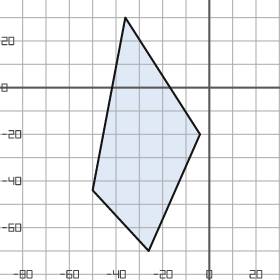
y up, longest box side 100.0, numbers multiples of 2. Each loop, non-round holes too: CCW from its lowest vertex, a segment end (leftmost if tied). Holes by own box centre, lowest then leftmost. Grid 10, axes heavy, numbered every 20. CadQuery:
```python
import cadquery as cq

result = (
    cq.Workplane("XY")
    .moveTo(-26.0, -70.0)
    .lineTo(-4.0, -20.0)
    .lineTo(-36.0, 30.0)
    .lineTo(-50.0, -44.0)
    .close()
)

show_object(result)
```